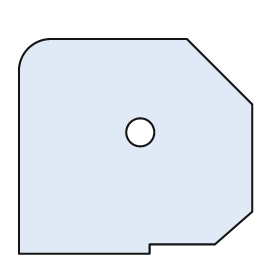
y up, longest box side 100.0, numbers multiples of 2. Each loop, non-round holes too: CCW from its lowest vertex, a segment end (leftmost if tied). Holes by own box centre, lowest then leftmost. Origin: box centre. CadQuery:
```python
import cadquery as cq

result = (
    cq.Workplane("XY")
    .moveTo(-50.0, -46.0)
    .lineTo(6.0, -46.0)
    .lineTo(6.0, -42.0)
    .lineTo(34.0, -42.0)
    .lineTo(50.0, -28.0)
    .lineTo(50.0, 18.0)
    .lineTo(22.0, 46.0)
    .lineTo(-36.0, 46.0)
    .threePointArc((-46.0, 42.0), (-50.0, 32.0))
    .close()
    .moveTo(2.0, 6.0)
    .circle(6.0)
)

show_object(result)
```